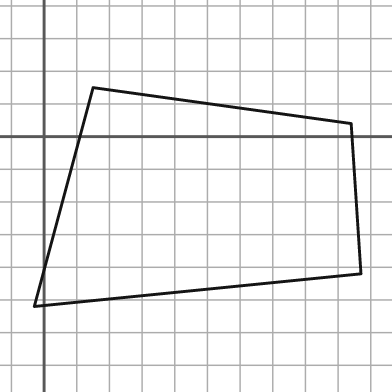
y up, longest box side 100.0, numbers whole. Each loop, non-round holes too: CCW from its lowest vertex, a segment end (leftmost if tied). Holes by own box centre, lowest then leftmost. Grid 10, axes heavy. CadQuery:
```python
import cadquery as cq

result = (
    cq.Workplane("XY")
    .moveTo(-3.0, -52.0)
    .lineTo(97.0, -42.0)
    .lineTo(94.0, 4.0)
    .lineTo(15.0, 15.0)
    .close()
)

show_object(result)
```